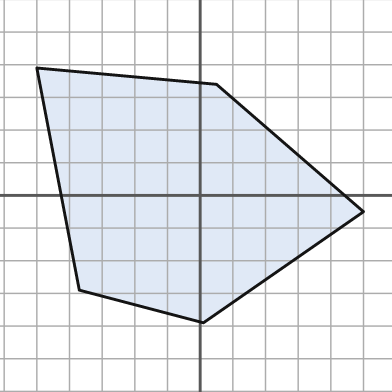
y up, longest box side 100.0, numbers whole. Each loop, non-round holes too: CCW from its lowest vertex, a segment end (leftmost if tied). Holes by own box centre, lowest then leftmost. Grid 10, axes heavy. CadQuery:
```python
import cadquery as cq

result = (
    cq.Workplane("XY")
    .moveTo(1.0, -39.0)
    .lineTo(50.0, -5.0)
    .lineTo(5.0, 34.0)
    .lineTo(-50.0, 39.0)
    .lineTo(-37.0, -29.0)
    .close()
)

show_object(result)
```